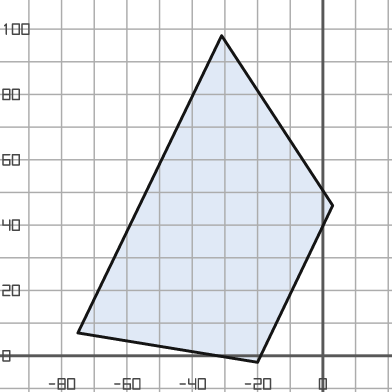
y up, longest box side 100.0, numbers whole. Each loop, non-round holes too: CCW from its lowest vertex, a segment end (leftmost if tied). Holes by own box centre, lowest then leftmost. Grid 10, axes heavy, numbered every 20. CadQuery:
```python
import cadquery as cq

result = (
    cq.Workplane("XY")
    .moveTo(-20.0, -2.0)
    .lineTo(3.0, 46.0)
    .lineTo(-31.0, 98.0)
    .lineTo(-75.0, 7.0)
    .close()
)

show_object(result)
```